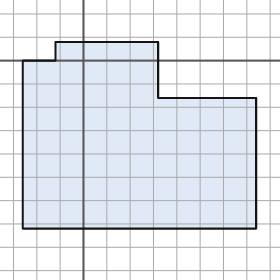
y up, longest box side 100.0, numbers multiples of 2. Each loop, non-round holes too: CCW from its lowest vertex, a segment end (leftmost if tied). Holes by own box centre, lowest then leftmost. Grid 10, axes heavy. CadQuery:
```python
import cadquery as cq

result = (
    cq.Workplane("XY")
    .moveTo(-26.0, -72.0)
    .lineTo(74.0, -72.0)
    .lineTo(74.0, -16.0)
    .lineTo(32.0, -16.0)
    .lineTo(32.0, 8.0)
    .lineTo(-12.0, 8.0)
    .lineTo(-12.0, 0.0)
    .lineTo(-26.0, 0.0)
    .close()
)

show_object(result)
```